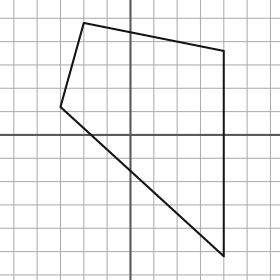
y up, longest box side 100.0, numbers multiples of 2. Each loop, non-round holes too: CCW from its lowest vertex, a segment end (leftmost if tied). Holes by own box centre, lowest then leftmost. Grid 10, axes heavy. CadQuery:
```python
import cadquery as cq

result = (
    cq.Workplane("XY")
    .moveTo(40.0, -52.0)
    .lineTo(40.0, 36.0)
    .lineTo(-20.0, 48.0)
    .lineTo(-30.0, 12.0)
    .close()
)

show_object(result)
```